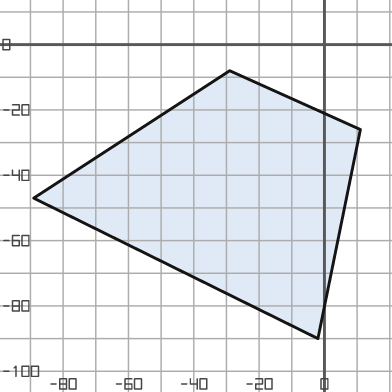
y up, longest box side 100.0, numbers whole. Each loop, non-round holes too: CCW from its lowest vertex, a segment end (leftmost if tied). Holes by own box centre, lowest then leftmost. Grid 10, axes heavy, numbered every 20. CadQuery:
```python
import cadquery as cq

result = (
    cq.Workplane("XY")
    .moveTo(-2.0, -90.0)
    .lineTo(11.0, -26.0)
    .lineTo(-29.0, -8.0)
    .lineTo(-89.0, -47.0)
    .close()
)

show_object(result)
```